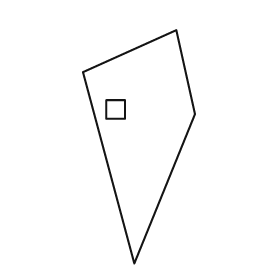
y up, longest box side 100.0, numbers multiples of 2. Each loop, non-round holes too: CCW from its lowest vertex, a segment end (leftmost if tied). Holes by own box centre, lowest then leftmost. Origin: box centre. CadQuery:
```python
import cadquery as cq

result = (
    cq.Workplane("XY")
    .moveTo(-2.0, -50.0)
    .lineTo(24.0, 14.0)
    .lineTo(16.0, 50.0)
    .lineTo(-24.0, 32.0)
    .close()
    .moveTo(-14.0, 12.0)
    .lineTo(-6.0, 12.0)
    .lineTo(-6.0, 20.0)
    .lineTo(-14.0, 20.0)
    .close()
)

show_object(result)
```